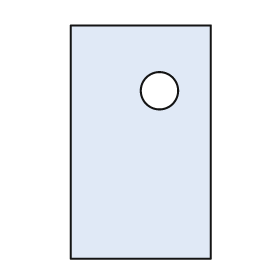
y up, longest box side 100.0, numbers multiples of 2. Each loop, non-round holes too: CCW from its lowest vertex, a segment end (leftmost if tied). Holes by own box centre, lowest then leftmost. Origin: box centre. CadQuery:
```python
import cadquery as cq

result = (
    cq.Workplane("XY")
    .moveTo(-30.0, -50.0)
    .lineTo(30.0, -50.0)
    .lineTo(30.0, 50.0)
    .lineTo(-30.0, 50.0)
    .close()
    .moveTo(8.0, 22.0)
    .circle(8.0)
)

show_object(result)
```